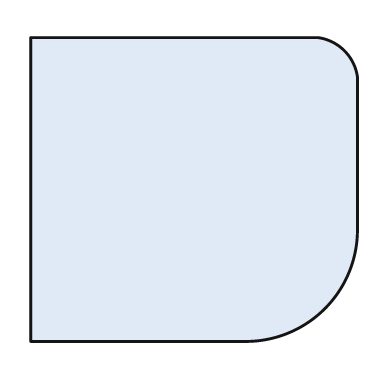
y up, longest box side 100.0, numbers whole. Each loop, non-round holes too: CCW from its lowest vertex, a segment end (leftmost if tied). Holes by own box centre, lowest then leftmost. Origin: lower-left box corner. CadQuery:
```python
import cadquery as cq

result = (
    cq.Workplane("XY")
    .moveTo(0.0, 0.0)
    .lineTo(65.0, 0.0)
    .threePointArc((90.0, 10.0), (100.0, 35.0))
    .lineTo(100.0, 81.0)
    .threePointArc((96.0, 89.0), (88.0, 93.0))
    .lineTo(0.0, 93.0)
    .close()
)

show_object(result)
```